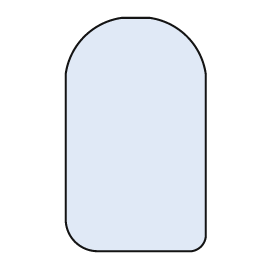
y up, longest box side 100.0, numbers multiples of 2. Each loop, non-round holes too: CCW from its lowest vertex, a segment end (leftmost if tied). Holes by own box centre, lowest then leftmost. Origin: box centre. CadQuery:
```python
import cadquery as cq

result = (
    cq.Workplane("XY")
    .moveTo(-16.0, -50.0)
    .lineTo(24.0, -50.0)
    .threePointArc((28.0, -48.0), (30.0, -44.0))
    .lineTo(30.0, 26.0)
    .threePointArc((22.0, 42.0), (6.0, 50.0))
    .lineTo(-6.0, 50.0)
    .threePointArc((-22.0, 42.0), (-30.0, 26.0))
    .lineTo(-30.0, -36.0)
    .threePointArc((-26.0, -46.0), (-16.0, -50.0))
    .close()
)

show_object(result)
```